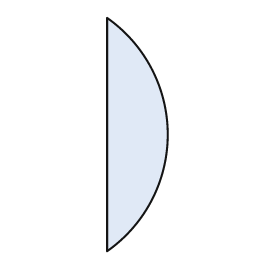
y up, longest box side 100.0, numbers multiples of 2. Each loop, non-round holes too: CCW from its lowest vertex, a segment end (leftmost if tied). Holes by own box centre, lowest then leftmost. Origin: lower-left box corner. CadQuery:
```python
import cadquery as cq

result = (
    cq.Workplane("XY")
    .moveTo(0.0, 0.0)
    .threePointArc((26.0, 50.0), (0.0, 100.0))
    .close()
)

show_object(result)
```